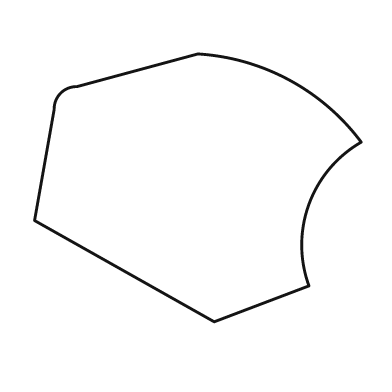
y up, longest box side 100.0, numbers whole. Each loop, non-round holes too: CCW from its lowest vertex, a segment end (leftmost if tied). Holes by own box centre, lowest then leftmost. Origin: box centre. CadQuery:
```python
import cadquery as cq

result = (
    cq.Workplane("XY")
    .moveTo(5.0, -41.0)
    .lineTo(34.0, -30.0)
    .threePointArc((34.0, -5.0), (50.0, 14.0))
    .threePointArc((28.0, 33.0), (0.0, 41.0))
    .lineTo(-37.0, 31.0)
    .threePointArc((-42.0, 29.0), (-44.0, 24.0))
    .lineTo(-50.0, -10.0)
    .close()
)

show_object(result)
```